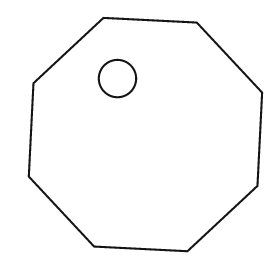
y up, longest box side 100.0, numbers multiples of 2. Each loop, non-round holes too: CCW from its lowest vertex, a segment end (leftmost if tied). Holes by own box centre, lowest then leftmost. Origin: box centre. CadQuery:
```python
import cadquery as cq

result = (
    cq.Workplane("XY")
    .moveTo(18.0, -50.0)
    .lineTo(48.0, -22.0)
    .lineTo(50.0, 18.0)
    .lineTo(22.0, 48.0)
    .lineTo(-18.0, 50.0)
    .lineTo(-48.0, 22.0)
    .lineTo(-50.0, -18.0)
    .lineTo(-22.0, -48.0)
    .close()
    .moveTo(-12.0, 24.0)
    .circle(8.0)
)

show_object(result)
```